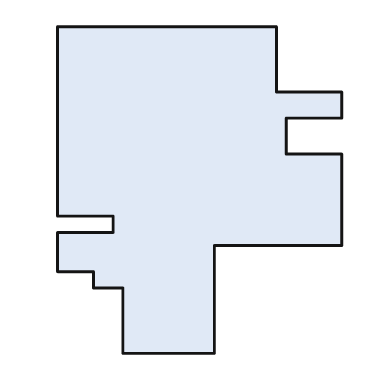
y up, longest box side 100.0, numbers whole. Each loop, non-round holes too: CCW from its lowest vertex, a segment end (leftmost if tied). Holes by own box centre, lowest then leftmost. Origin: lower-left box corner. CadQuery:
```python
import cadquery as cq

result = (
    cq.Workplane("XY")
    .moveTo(20.0, 0.0)
    .lineTo(48.0, 0.0)
    .lineTo(48.0, 33.0)
    .lineTo(87.0, 33.0)
    .lineTo(87.0, 61.0)
    .lineTo(70.0, 61.0)
    .lineTo(70.0, 72.0)
    .lineTo(87.0, 72.0)
    .lineTo(87.0, 80.0)
    .lineTo(67.0, 80.0)
    .lineTo(67.0, 100.0)
    .lineTo(0.0, 100.0)
    .lineTo(0.0, 42.0)
    .lineTo(17.0, 42.0)
    .lineTo(17.0, 37.0)
    .lineTo(0.0, 37.0)
    .lineTo(0.0, 25.0)
    .lineTo(11.0, 25.0)
    .lineTo(11.0, 20.0)
    .lineTo(20.0, 20.0)
    .close()
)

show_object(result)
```